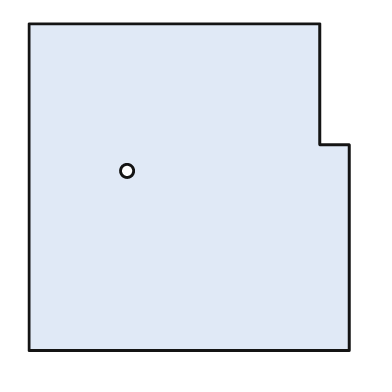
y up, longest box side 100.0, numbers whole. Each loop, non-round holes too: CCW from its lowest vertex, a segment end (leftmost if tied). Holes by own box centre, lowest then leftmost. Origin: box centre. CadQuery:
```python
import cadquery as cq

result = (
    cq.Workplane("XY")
    .moveTo(-49.0, -50.0)
    .lineTo(49.0, -50.0)
    .lineTo(49.0, 13.0)
    .lineTo(40.0, 13.0)
    .lineTo(40.0, 50.0)
    .lineTo(-49.0, 50.0)
    .close()
    .moveTo(-19.0, 5.0)
    .circle(2.0)
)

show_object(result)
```